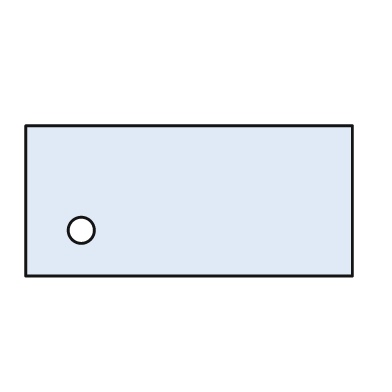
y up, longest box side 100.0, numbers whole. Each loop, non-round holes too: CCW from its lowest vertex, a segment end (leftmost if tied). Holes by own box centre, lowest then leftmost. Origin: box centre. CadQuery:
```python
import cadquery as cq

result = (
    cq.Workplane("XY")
    .moveTo(-50.0, -23.0)
    .lineTo(50.0, -23.0)
    .lineTo(50.0, 23.0)
    .lineTo(-50.0, 23.0)
    .close()
    .moveTo(-33.0, -9.0)
    .circle(4.0)
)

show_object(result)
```